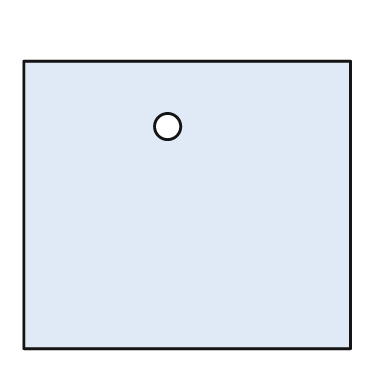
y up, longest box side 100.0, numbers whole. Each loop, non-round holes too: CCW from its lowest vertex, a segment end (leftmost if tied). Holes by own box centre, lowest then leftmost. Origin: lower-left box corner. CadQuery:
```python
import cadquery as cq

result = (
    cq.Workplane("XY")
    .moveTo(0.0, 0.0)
    .lineTo(100.0, 0.0)
    .lineTo(100.0, 88.0)
    .lineTo(0.0, 88.0)
    .close()
    .moveTo(44.0, 68.0)
    .circle(4.0)
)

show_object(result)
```